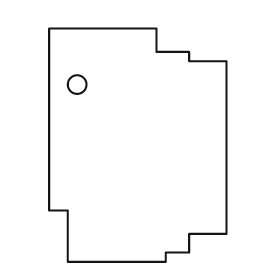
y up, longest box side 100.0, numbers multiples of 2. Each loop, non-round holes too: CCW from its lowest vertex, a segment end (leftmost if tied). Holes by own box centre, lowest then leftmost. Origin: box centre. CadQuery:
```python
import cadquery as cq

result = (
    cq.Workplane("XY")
    .moveTo(-30.0, -50.0)
    .lineTo(12.0, -50.0)
    .lineTo(12.0, -46.0)
    .lineTo(22.0, -46.0)
    .lineTo(22.0, -38.0)
    .lineTo(38.0, -38.0)
    .lineTo(38.0, 36.0)
    .lineTo(22.0, 36.0)
    .lineTo(22.0, 40.0)
    .lineTo(8.0, 40.0)
    .lineTo(8.0, 50.0)
    .lineTo(-38.0, 50.0)
    .lineTo(-38.0, -28.0)
    .lineTo(-30.0, -28.0)
    .close()
    .moveTo(-26.0, 26.0)
    .circle(4.0)
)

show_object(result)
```